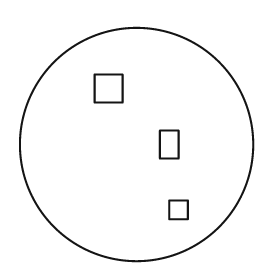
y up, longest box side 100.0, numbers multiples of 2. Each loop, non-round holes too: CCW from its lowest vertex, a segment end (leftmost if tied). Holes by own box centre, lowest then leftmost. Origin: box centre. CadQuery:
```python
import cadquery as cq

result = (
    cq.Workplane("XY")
    .moveTo(0.0, 0.0)
    .circle(50.0)
    .moveTo(14.0, -32.0)
    .lineTo(22.0, -32.0)
    .lineTo(22.0, -24.0)
    .lineTo(14.0, -24.0)
    .close()
    .moveTo(10.0, -6.0)
    .lineTo(18.0, -6.0)
    .lineTo(18.0, 6.0)
    .lineTo(10.0, 6.0)
    .close()
    .moveTo(-18.0, 18.0)
    .lineTo(-6.0, 18.0)
    .lineTo(-6.0, 30.0)
    .lineTo(-18.0, 30.0)
    .close()
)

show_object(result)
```